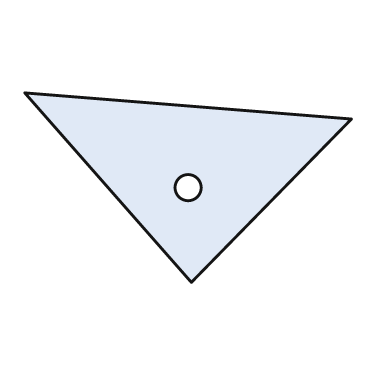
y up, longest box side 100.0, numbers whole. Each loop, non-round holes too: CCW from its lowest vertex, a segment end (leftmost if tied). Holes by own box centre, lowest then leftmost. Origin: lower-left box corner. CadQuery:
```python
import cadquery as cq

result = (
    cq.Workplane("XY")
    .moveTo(51.0, 0.0)
    .lineTo(100.0, 50.0)
    .lineTo(0.0, 58.0)
    .close()
    .moveTo(50.0, 29.0)
    .circle(4.0)
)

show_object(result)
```